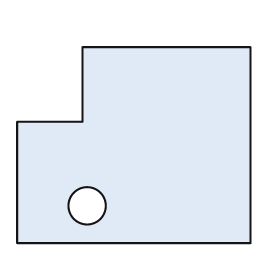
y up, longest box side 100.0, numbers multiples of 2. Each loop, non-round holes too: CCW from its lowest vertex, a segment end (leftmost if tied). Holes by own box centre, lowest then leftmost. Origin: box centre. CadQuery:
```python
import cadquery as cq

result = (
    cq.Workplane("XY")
    .moveTo(-50.0, -42.0)
    .lineTo(50.0, -42.0)
    .lineTo(50.0, 42.0)
    .lineTo(-22.0, 42.0)
    .lineTo(-22.0, 10.0)
    .lineTo(-50.0, 10.0)
    .close()
    .moveTo(-20.0, -26.0)
    .circle(8.0)
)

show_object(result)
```